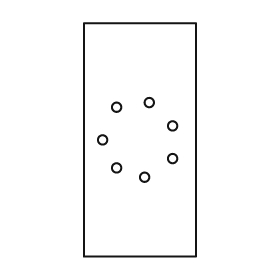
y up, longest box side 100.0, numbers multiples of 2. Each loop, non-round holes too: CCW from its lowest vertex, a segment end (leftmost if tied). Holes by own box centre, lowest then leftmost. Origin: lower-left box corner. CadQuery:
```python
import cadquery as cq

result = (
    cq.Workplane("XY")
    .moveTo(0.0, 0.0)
    .lineTo(48.0, 0.0)
    .lineTo(48.0, 100.0)
    .lineTo(0.0, 100.0)
    .close()
    .moveTo(26.0, 34.0)
    .circle(2.0)
    .moveTo(14.0, 38.0)
    .circle(2.0)
    .moveTo(38.0, 42.0)
    .circle(2.0)
    .moveTo(8.0, 50.0)
    .circle(2.0)
    .moveTo(38.0, 56.0)
    .circle(2.0)
    .moveTo(14.0, 64.0)
    .circle(2.0)
    .moveTo(28.0, 66.0)
    .circle(2.0)
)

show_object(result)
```